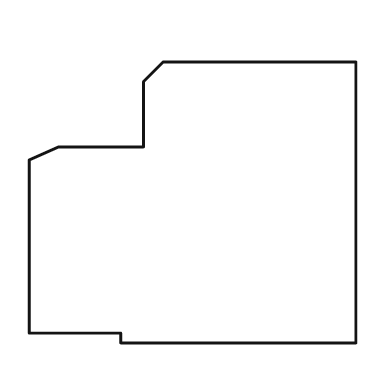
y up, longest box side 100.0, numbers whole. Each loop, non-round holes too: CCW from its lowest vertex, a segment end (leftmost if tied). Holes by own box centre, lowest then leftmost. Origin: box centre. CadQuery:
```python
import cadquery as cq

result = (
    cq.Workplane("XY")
    .moveTo(-22.0, -43.0)
    .lineTo(50.0, -43.0)
    .lineTo(50.0, 43.0)
    .lineTo(-9.0, 43.0)
    .lineTo(-15.0, 37.0)
    .lineTo(-15.0, 17.0)
    .lineTo(-41.0, 17.0)
    .lineTo(-50.0, 13.0)
    .lineTo(-50.0, -40.0)
    .lineTo(-22.0, -40.0)
    .close()
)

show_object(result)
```